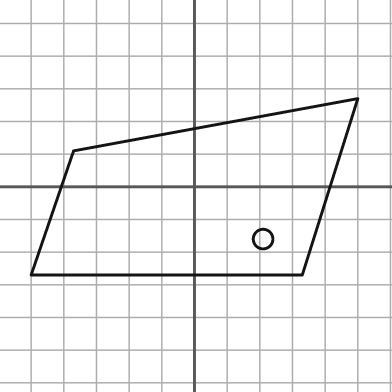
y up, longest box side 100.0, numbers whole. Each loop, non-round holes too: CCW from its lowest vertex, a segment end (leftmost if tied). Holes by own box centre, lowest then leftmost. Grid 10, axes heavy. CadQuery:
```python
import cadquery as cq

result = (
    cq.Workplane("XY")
    .moveTo(-50.0, -27.0)
    .lineTo(33.0, -27.0)
    .lineTo(50.0, 27.0)
    .lineTo(-37.0, 11.0)
    .close()
    .moveTo(21.0, -16.0)
    .circle(3.0)
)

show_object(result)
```